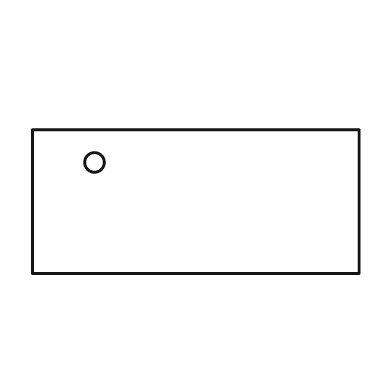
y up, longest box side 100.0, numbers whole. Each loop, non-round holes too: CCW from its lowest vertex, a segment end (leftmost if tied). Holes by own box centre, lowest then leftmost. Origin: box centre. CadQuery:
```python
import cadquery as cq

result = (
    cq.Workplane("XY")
    .moveTo(-50.0, -22.0)
    .lineTo(50.0, -22.0)
    .lineTo(50.0, 22.0)
    .lineTo(-50.0, 22.0)
    .close()
    .moveTo(-31.0, 12.0)
    .circle(3.0)
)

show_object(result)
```